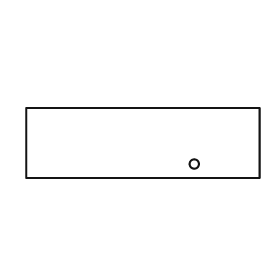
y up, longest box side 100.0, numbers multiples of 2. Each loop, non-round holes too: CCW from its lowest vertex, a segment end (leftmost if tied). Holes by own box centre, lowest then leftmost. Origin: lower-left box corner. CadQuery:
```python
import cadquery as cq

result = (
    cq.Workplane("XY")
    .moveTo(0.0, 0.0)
    .lineTo(100.0, 0.0)
    .lineTo(100.0, 30.0)
    .lineTo(0.0, 30.0)
    .close()
    .moveTo(72.0, 6.0)
    .circle(2.0)
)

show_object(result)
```